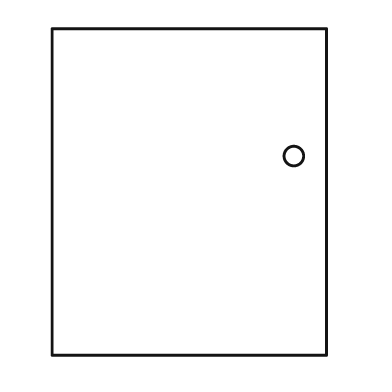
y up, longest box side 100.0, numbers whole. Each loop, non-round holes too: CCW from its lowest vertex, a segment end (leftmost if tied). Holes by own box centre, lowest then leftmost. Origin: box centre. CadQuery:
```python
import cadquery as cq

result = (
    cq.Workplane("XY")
    .moveTo(-42.0, -50.0)
    .lineTo(42.0, -50.0)
    .lineTo(42.0, 50.0)
    .lineTo(-42.0, 50.0)
    .close()
    .moveTo(32.0, 11.0)
    .circle(3.0)
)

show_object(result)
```